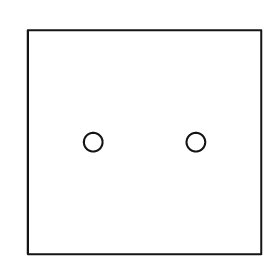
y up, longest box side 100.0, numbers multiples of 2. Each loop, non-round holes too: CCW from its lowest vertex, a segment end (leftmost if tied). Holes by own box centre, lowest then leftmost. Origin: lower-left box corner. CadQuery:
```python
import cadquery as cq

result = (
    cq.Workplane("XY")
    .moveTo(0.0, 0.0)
    .lineTo(100.0, 0.0)
    .lineTo(100.0, 96.0)
    .lineTo(0.0, 96.0)
    .close()
    .moveTo(28.0, 48.0)
    .circle(4.0)
    .moveTo(72.0, 48.0)
    .circle(4.0)
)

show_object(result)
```